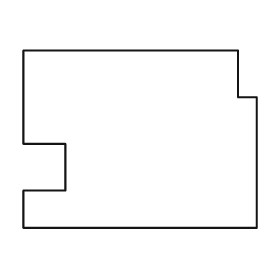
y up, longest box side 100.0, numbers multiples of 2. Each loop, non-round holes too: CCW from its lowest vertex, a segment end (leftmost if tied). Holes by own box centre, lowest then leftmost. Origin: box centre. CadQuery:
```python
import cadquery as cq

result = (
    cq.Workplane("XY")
    .moveTo(-50.0, -38.0)
    .lineTo(50.0, -38.0)
    .lineTo(50.0, 18.0)
    .lineTo(42.0, 18.0)
    .lineTo(42.0, 38.0)
    .lineTo(-50.0, 38.0)
    .lineTo(-50.0, -2.0)
    .lineTo(-32.0, -2.0)
    .lineTo(-32.0, -22.0)
    .lineTo(-50.0, -22.0)
    .close()
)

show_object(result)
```